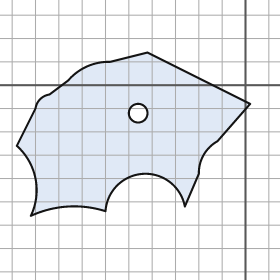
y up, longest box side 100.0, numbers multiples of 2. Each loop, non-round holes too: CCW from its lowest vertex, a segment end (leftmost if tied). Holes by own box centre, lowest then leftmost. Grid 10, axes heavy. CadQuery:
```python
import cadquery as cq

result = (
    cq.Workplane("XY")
    .moveTo(-92.0, -56.0)
    .threePointArc((-76.0, -52.0), (-60.0, -54.0))
    .threePointArc((-44.0, -38.0), (-26.0, -52.0))
    .lineTo(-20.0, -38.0)
    .threePointArc((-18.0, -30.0), (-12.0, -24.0))
    .lineTo(2.0, -8.0)
    .lineTo(-42.0, 14.0)
    .lineTo(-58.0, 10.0)
    .threePointArc((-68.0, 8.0), (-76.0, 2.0))
    .lineTo(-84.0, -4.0)
    .threePointArc((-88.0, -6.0), (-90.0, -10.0))
    .lineTo(-98.0, -26.0)
    .threePointArc((-90.0, -40.0), (-92.0, -56.0))
    .close()
    .moveTo(-46.0, -12.0)
    .circle(4.0)
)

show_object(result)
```